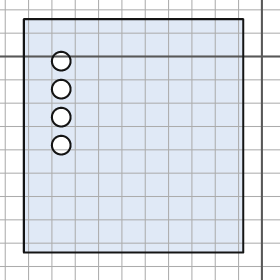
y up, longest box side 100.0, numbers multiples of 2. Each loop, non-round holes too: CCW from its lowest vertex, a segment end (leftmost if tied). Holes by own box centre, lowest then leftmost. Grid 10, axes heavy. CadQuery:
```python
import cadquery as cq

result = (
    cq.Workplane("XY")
    .moveTo(-102.0, -84.0)
    .lineTo(-8.0, -84.0)
    .lineTo(-8.0, 16.0)
    .lineTo(-102.0, 16.0)
    .close()
    .moveTo(-86.0, -38.0)
    .circle(4.0)
    .moveTo(-86.0, -26.0)
    .circle(4.0)
    .moveTo(-86.0, -14.0)
    .circle(4.0)
    .moveTo(-86.0, -2.0)
    .circle(4.0)
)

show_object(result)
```